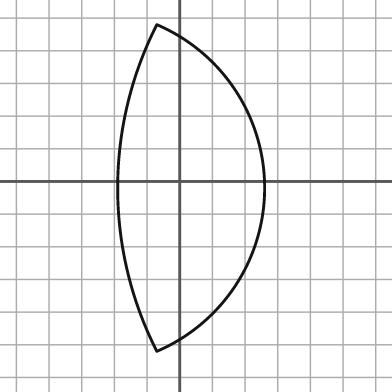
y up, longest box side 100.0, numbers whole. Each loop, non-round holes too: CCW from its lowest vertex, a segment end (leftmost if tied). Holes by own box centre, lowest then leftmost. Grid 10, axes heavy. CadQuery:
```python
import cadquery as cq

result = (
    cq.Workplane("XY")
    .moveTo(-7.0, -52.0)
    .threePointArc((26.0, -2.0), (-7.0, 48.0))
    .threePointArc((-19.0, -2.0), (-7.0, -52.0))
    .close()
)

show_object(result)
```